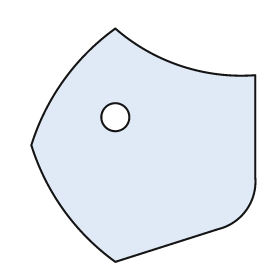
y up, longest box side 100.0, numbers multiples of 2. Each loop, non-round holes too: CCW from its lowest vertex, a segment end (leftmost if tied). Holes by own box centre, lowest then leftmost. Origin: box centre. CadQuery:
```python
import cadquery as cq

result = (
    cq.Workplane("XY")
    .moveTo(-12.0, -50.0)
    .lineTo(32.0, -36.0)
    .threePointArc((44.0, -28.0), (48.0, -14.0))
    .lineTo(48.0, 30.0)
    .threePointArc((16.0, 34.0), (-12.0, 50.0))
    .threePointArc((-34.0, 28.0), (-48.0, 0.0))
    .threePointArc((-34.0, -28.0), (-12.0, -50.0))
    .close()
    .moveTo(-12.0, 12.0)
    .circle(6.0)
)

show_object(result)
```